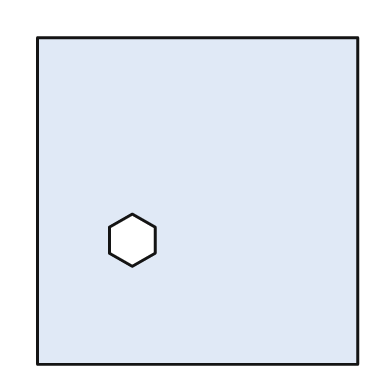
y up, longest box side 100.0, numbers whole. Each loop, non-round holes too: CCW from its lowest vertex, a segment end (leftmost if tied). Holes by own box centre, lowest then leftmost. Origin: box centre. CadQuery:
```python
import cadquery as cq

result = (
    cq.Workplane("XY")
    .moveTo(-49.0, -50.0)
    .lineTo(49.0, -50.0)
    .lineTo(49.0, 50.0)
    .lineTo(-49.0, 50.0)
    .close()
    .moveTo(-20.0, -20.0)
    .lineTo(-13.0, -16.0)
    .lineTo(-13.0, -8.0)
    .lineTo(-20.0, -4.0)
    .lineTo(-27.0, -8.0)
    .lineTo(-27.0, -16.0)
    .close()
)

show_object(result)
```